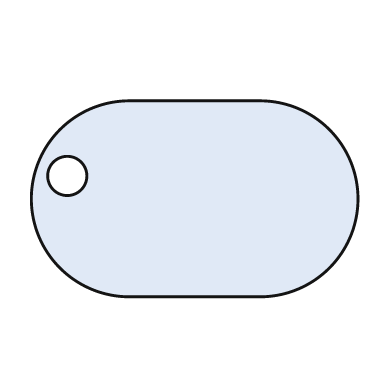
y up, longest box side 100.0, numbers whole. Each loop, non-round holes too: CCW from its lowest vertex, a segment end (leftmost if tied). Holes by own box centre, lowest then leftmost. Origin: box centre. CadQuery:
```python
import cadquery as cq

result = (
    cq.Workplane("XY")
    .moveTo(-20.0, -30.0)
    .lineTo(20.0, -30.0)
    .threePointArc((50.0, 0.0), (20.0, 30.0))
    .lineTo(-20.0, 30.0)
    .threePointArc((-50.0, 0.0), (-20.0, -30.0))
    .close()
    .moveTo(-39.0, 7.0)
    .circle(6.0)
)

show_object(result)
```